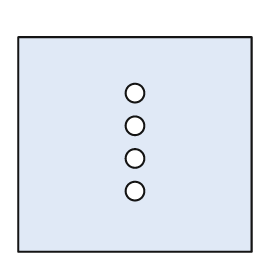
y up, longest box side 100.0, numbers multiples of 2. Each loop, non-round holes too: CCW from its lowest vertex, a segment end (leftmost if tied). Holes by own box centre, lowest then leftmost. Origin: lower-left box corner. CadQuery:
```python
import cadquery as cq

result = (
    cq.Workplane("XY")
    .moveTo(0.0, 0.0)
    .lineTo(100.0, 0.0)
    .lineTo(100.0, 92.0)
    .lineTo(0.0, 92.0)
    .close()
    .moveTo(50.0, 26.0)
    .circle(4.0)
    .moveTo(50.0, 40.0)
    .circle(4.0)
    .moveTo(50.0, 54.0)
    .circle(4.0)
    .moveTo(50.0, 68.0)
    .circle(4.0)
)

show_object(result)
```